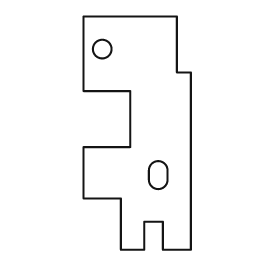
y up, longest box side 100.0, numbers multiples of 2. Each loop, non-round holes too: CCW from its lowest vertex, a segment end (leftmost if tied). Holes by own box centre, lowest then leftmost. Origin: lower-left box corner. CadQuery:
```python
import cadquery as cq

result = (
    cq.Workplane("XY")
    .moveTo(16.0, 0.0)
    .lineTo(26.0, 0.0)
    .lineTo(26.0, 12.0)
    .lineTo(34.0, 12.0)
    .lineTo(34.0, 0.0)
    .lineTo(46.0, 0.0)
    .lineTo(46.0, 76.0)
    .lineTo(40.0, 76.0)
    .lineTo(40.0, 100.0)
    .lineTo(0.0, 100.0)
    .lineTo(0.0, 68.0)
    .lineTo(20.0, 68.0)
    .lineTo(20.0, 44.0)
    .lineTo(0.0, 44.0)
    .lineTo(0.0, 22.0)
    .lineTo(16.0, 22.0)
    .close()
    .moveTo(28.0, 30.0)
    .threePointArc((32.0, 26.0), (36.0, 30.0))
    .lineTo(36.0, 34.0)
    .threePointArc((32.0, 38.0), (28.0, 34.0))
    .close()
    .moveTo(8.0, 86.0)
    .circle(4.0)
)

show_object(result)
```